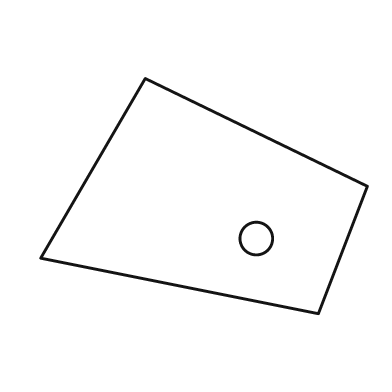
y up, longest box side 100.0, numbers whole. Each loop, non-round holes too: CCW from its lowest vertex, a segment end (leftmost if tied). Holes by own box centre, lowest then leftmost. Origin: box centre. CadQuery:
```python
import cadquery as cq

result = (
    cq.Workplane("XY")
    .moveTo(35.0, -36.0)
    .lineTo(50.0, 3.0)
    .lineTo(-18.0, 36.0)
    .lineTo(-50.0, -19.0)
    .close()
    .moveTo(16.0, -13.0)
    .circle(5.0)
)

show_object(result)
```